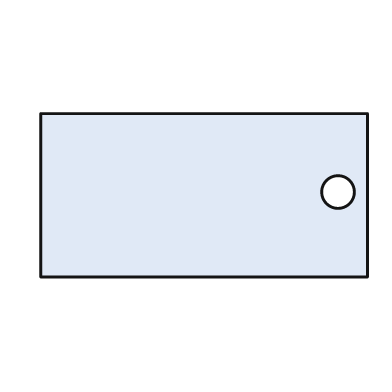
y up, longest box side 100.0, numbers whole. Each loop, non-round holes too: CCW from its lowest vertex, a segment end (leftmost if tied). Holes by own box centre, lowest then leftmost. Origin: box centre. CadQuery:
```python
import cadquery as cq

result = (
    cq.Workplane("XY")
    .moveTo(-50.0, -25.0)
    .lineTo(50.0, -25.0)
    .lineTo(50.0, 25.0)
    .lineTo(-50.0, 25.0)
    .close()
    .moveTo(41.0, 1.0)
    .circle(5.0)
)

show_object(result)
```